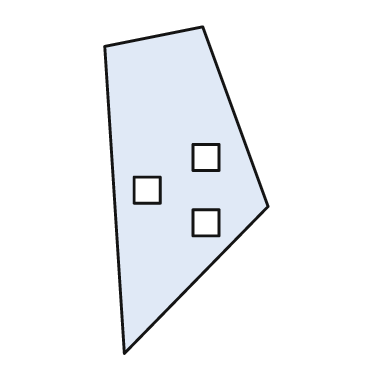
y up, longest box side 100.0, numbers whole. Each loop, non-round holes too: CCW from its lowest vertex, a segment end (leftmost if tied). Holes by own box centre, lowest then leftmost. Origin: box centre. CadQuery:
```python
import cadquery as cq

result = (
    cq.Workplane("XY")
    .moveTo(-19.0, -50.0)
    .lineTo(25.0, -5.0)
    .lineTo(5.0, 50.0)
    .lineTo(-25.0, 44.0)
    .close()
    .moveTo(2.0, -14.0)
    .lineTo(10.0, -14.0)
    .lineTo(10.0, -6.0)
    .lineTo(2.0, -6.0)
    .close()
    .moveTo(-16.0, -4.0)
    .lineTo(-8.0, -4.0)
    .lineTo(-8.0, 4.0)
    .lineTo(-16.0, 4.0)
    .close()
    .moveTo(2.0, 6.0)
    .lineTo(10.0, 6.0)
    .lineTo(10.0, 14.0)
    .lineTo(2.0, 14.0)
    .close()
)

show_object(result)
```